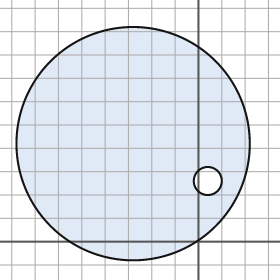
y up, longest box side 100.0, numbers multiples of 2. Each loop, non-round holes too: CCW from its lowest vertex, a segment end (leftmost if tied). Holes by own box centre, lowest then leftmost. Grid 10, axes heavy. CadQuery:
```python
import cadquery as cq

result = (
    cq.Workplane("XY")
    .moveTo(-28.0, 42.0)
    .circle(50.0)
    .moveTo(4.0, 26.0)
    .circle(6.0)
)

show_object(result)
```